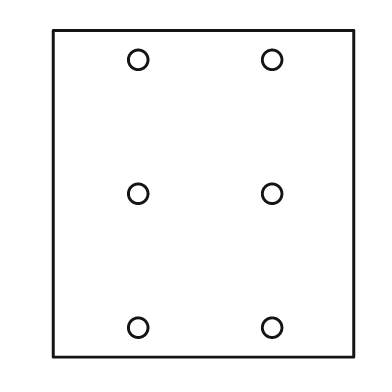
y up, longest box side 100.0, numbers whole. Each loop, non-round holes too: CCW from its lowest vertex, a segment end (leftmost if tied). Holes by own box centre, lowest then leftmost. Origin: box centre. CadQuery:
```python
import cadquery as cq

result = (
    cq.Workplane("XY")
    .moveTo(-46.0, -50.0)
    .lineTo(46.0, -50.0)
    .lineTo(46.0, 50.0)
    .lineTo(-46.0, 50.0)
    .close()
    .moveTo(-20.0, -41.0)
    .circle(3.0)
    .moveTo(21.0, -41.0)
    .circle(3.0)
    .moveTo(-20.0, 0.0)
    .circle(3.0)
    .moveTo(21.0, 0.0)
    .circle(3.0)
    .moveTo(-20.0, 41.0)
    .circle(3.0)
    .moveTo(21.0, 41.0)
    .circle(3.0)
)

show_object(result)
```